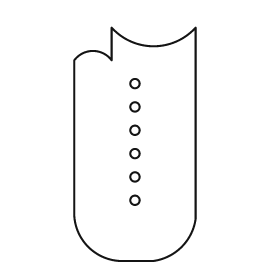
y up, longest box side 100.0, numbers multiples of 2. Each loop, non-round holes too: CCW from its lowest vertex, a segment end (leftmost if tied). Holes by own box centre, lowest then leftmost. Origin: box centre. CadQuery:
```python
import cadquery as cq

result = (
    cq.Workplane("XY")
    .moveTo(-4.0, -50.0)
    .lineTo(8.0, -50.0)
    .threePointArc((20.0, -44.0), (26.0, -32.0))
    .lineTo(26.0, 50.0)
    .threePointArc((8.0, 42.0), (-10.0, 50.0))
    .lineTo(-10.0, 36.0)
    .threePointArc((-18.0, 40.0), (-26.0, 36.0))
    .lineTo(-26.0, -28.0)
    .threePointArc((-20.0, -44.0), (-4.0, -50.0))
    .close()
    .moveTo(0.0, -24.0)
    .circle(2.0)
    .moveTo(0.0, -14.0)
    .circle(2.0)
    .moveTo(0.0, -4.0)
    .circle(2.0)
    .moveTo(0.0, 6.0)
    .circle(2.0)
    .moveTo(0.0, 16.0)
    .circle(2.0)
    .moveTo(0.0, 26.0)
    .circle(2.0)
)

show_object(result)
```